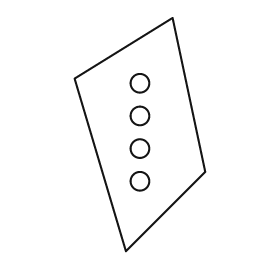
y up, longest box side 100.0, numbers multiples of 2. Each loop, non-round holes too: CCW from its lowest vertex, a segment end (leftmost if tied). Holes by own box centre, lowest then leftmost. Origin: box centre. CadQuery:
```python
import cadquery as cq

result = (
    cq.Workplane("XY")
    .moveTo(-6.0, -50.0)
    .lineTo(28.0, -16.0)
    .lineTo(14.0, 50.0)
    .lineTo(-28.0, 24.0)
    .close()
    .moveTo(0.0, -20.0)
    .circle(4.0)
    .moveTo(0.0, -6.0)
    .circle(4.0)
    .moveTo(0.0, 8.0)
    .circle(4.0)
    .moveTo(0.0, 22.0)
    .circle(4.0)
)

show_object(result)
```